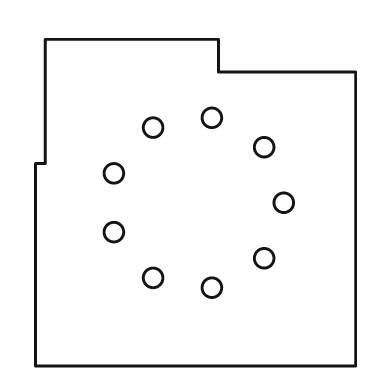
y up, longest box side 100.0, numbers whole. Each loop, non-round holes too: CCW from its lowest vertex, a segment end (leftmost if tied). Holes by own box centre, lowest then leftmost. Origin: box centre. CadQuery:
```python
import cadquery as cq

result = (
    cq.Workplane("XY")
    .moveTo(-49.0, -50.0)
    .lineTo(49.0, -50.0)
    .lineTo(49.0, 40.0)
    .lineTo(7.0, 40.0)
    .lineTo(7.0, 50.0)
    .lineTo(-46.0, 50.0)
    .lineTo(-46.0, 12.0)
    .lineTo(-49.0, 12.0)
    .close()
    .moveTo(5.0, -26.0)
    .circle(3.0)
    .moveTo(-13.0, -23.0)
    .circle(3.0)
    .moveTo(21.0, -17.0)
    .circle(3.0)
    .moveTo(-25.0, -9.0)
    .circle(3.0)
    .moveTo(27.0, 0.0)
    .circle(3.0)
    .moveTo(-25.0, 9.0)
    .circle(3.0)
    .moveTo(21.0, 17.0)
    .circle(3.0)
    .moveTo(-13.0, 23.0)
    .circle(3.0)
    .moveTo(5.0, 26.0)
    .circle(3.0)
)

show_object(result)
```